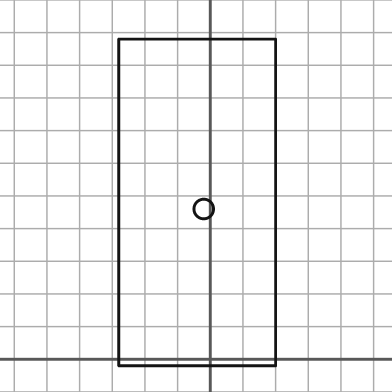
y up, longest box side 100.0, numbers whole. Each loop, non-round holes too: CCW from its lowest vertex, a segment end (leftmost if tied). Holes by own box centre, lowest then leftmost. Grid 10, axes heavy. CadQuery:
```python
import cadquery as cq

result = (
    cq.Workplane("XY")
    .moveTo(-28.0, -2.0)
    .lineTo(20.0, -2.0)
    .lineTo(20.0, 98.0)
    .lineTo(-28.0, 98.0)
    .close()
    .moveTo(-2.0, 46.0)
    .circle(3.0)
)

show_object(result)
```